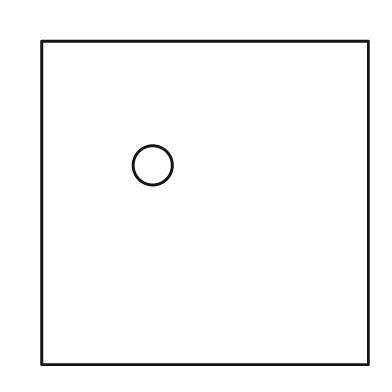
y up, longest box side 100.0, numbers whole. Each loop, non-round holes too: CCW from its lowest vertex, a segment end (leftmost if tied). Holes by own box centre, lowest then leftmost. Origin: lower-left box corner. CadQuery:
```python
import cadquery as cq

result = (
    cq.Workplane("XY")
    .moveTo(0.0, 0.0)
    .lineTo(100.0, 0.0)
    .lineTo(100.0, 99.0)
    .lineTo(0.0, 99.0)
    .close()
    .moveTo(34.0, 61.0)
    .circle(6.0)
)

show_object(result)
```